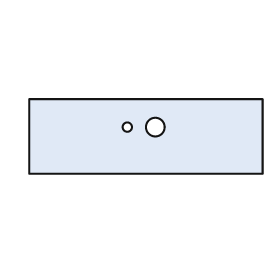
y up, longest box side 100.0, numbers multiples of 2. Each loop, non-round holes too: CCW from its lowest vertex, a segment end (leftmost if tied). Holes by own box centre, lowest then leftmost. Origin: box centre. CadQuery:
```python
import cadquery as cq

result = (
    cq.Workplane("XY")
    .moveTo(-50.0, -16.0)
    .lineTo(50.0, -16.0)
    .lineTo(50.0, 16.0)
    .lineTo(-50.0, 16.0)
    .close()
    .moveTo(-8.0, 4.0)
    .circle(2.0)
    .moveTo(4.0, 4.0)
    .circle(4.0)
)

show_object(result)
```